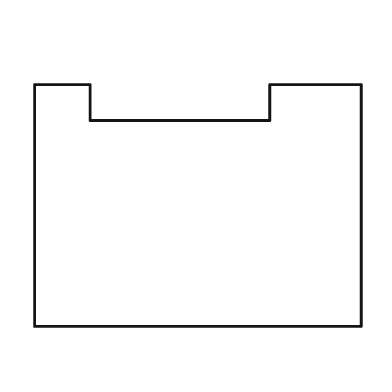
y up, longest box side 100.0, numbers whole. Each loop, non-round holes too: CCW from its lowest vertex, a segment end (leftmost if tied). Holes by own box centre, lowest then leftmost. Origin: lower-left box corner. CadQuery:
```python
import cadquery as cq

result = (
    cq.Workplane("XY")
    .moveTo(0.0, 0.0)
    .lineTo(100.0, 0.0)
    .lineTo(100.0, 74.0)
    .lineTo(72.0, 74.0)
    .lineTo(72.0, 63.0)
    .lineTo(17.0, 63.0)
    .lineTo(17.0, 74.0)
    .lineTo(0.0, 74.0)
    .close()
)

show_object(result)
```